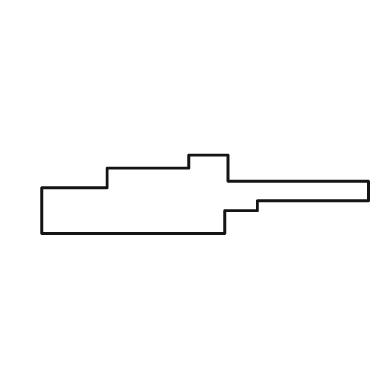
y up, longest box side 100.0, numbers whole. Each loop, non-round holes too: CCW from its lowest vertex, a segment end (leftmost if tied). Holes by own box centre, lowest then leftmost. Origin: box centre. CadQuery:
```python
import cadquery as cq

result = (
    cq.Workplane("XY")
    .moveTo(-50.0, -12.0)
    .lineTo(6.0, -12.0)
    .lineTo(6.0, -5.0)
    .lineTo(16.0, -5.0)
    .lineTo(16.0, -2.0)
    .lineTo(50.0, -2.0)
    .lineTo(50.0, 4.0)
    .lineTo(7.0, 4.0)
    .lineTo(7.0, 12.0)
    .lineTo(-5.0, 12.0)
    .lineTo(-5.0, 8.0)
    .lineTo(-30.0, 8.0)
    .lineTo(-30.0, 2.0)
    .lineTo(-50.0, 2.0)
    .close()
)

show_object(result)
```